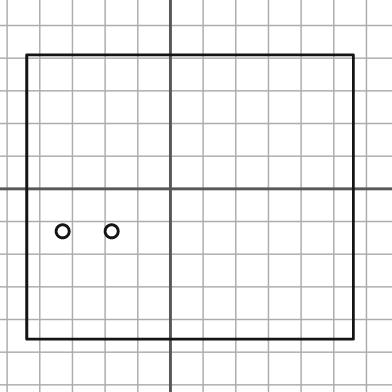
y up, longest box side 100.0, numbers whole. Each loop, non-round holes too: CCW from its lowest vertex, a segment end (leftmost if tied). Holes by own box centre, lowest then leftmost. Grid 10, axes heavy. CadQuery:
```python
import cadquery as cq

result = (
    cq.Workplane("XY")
    .moveTo(-44.0, -46.0)
    .lineTo(56.0, -46.0)
    .lineTo(56.0, 41.0)
    .lineTo(-44.0, 41.0)
    .close()
    .moveTo(-33.0, -13.0)
    .circle(2.0)
    .moveTo(-18.0, -13.0)
    .circle(2.0)
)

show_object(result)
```